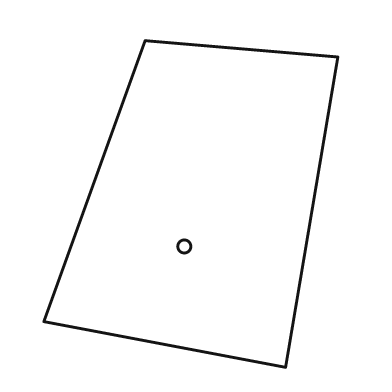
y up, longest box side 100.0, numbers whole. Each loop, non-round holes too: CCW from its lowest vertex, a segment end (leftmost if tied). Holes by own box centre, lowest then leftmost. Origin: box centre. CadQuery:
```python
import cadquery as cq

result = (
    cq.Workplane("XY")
    .moveTo(29.0, -50.0)
    .lineTo(45.0, 45.0)
    .lineTo(-14.0, 50.0)
    .lineTo(-45.0, -36.0)
    .close()
    .moveTo(-2.0, -13.0)
    .circle(2.0)
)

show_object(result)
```